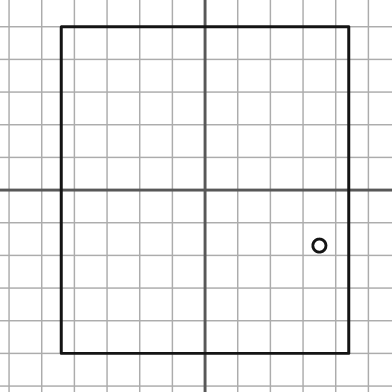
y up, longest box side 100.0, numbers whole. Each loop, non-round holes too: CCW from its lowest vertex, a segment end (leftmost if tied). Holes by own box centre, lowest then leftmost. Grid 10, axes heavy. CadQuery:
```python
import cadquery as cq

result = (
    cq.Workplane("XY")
    .moveTo(-44.0, -50.0)
    .lineTo(44.0, -50.0)
    .lineTo(44.0, 50.0)
    .lineTo(-44.0, 50.0)
    .close()
    .moveTo(35.0, -17.0)
    .circle(2.0)
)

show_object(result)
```